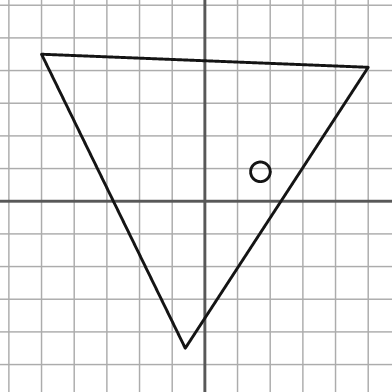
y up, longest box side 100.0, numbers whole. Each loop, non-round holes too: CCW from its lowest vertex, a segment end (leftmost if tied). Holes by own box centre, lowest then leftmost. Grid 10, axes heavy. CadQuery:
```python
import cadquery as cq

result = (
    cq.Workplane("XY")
    .moveTo(-6.0, -45.0)
    .lineTo(50.0, 41.0)
    .lineTo(-50.0, 45.0)
    .close()
    .moveTo(17.0, 9.0)
    .circle(3.0)
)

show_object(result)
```